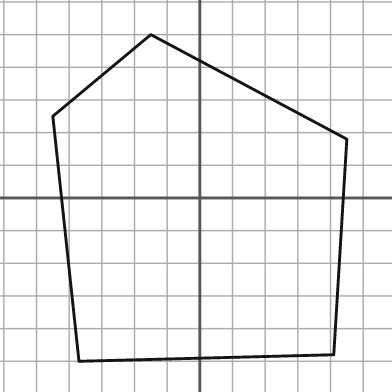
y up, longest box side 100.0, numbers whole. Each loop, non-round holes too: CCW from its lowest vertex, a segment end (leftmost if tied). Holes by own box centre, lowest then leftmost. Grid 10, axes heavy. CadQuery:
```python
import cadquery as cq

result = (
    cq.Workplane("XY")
    .moveTo(-37.0, -50.0)
    .lineTo(41.0, -48.0)
    .lineTo(45.0, 18.0)
    .lineTo(-15.0, 50.0)
    .lineTo(-45.0, 25.0)
    .close()
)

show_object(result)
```